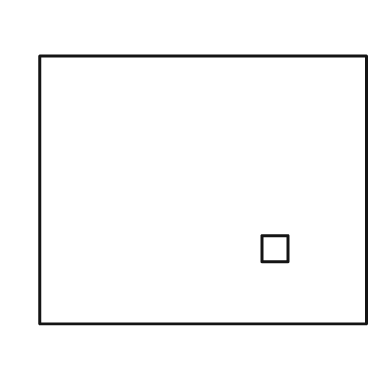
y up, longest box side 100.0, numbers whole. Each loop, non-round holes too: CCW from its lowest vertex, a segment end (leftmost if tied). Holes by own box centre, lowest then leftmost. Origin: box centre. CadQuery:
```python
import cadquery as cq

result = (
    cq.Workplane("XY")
    .moveTo(-50.0, -41.0)
    .lineTo(50.0, -41.0)
    .lineTo(50.0, 41.0)
    .lineTo(-50.0, 41.0)
    .close()
    .moveTo(18.0, -22.0)
    .lineTo(26.0, -22.0)
    .lineTo(26.0, -14.0)
    .lineTo(18.0, -14.0)
    .close()
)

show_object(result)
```